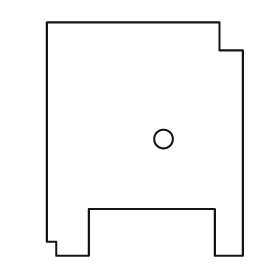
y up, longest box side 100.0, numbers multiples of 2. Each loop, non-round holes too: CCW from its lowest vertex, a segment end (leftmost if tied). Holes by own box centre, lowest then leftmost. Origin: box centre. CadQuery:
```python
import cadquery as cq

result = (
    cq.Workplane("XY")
    .moveTo(-38.0, -50.0)
    .lineTo(-24.0, -50.0)
    .lineTo(-24.0, -30.0)
    .lineTo(30.0, -30.0)
    .lineTo(30.0, -50.0)
    .lineTo(42.0, -50.0)
    .lineTo(42.0, 38.0)
    .lineTo(32.0, 38.0)
    .lineTo(32.0, 50.0)
    .lineTo(-42.0, 50.0)
    .lineTo(-42.0, -44.0)
    .lineTo(-38.0, -44.0)
    .close()
    .moveTo(8.0, 0.0)
    .circle(4.0)
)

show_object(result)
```